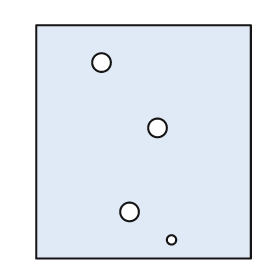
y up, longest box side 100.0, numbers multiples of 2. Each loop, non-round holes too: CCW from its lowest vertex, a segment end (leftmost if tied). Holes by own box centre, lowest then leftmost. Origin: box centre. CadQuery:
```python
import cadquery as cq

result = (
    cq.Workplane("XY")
    .moveTo(-46.0, -50.0)
    .lineTo(46.0, -50.0)
    .lineTo(46.0, 50.0)
    .lineTo(-46.0, 50.0)
    .close()
    .moveTo(12.0, -42.0)
    .circle(2.0)
    .moveTo(-6.0, -30.0)
    .circle(4.0)
    .moveTo(6.0, 6.0)
    .circle(4.0)
    .moveTo(-18.0, 34.0)
    .circle(4.0)
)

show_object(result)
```